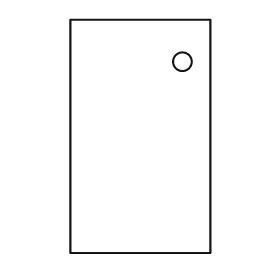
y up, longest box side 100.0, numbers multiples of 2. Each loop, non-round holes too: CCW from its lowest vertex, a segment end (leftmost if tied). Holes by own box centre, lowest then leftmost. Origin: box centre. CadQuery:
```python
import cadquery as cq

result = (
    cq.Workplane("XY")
    .moveTo(-30.0, -50.0)
    .lineTo(30.0, -50.0)
    .lineTo(30.0, 50.0)
    .lineTo(-30.0, 50.0)
    .close()
    .moveTo(18.0, 32.0)
    .circle(4.0)
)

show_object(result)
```